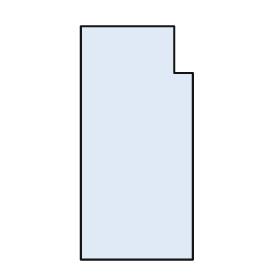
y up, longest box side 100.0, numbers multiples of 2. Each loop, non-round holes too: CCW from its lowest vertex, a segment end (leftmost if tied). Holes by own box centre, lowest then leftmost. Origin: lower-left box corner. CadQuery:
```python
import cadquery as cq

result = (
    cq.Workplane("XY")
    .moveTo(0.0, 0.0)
    .lineTo(48.0, 0.0)
    .lineTo(48.0, 80.0)
    .lineTo(40.0, 80.0)
    .lineTo(40.0, 100.0)
    .lineTo(0.0, 100.0)
    .close()
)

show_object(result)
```